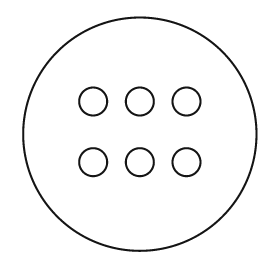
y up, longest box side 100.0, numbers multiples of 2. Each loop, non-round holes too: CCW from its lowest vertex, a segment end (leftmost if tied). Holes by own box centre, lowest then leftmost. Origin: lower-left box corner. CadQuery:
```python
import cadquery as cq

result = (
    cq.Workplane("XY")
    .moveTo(50.0, 50.0)
    .circle(50.0)
    .moveTo(30.0, 38.0)
    .circle(6.0)
    .moveTo(50.0, 38.0)
    .circle(6.0)
    .moveTo(70.0, 38.0)
    .circle(6.0)
    .moveTo(30.0, 64.0)
    .circle(6.0)
    .moveTo(50.0, 64.0)
    .circle(6.0)
    .moveTo(70.0, 64.0)
    .circle(6.0)
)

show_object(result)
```